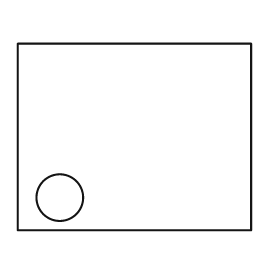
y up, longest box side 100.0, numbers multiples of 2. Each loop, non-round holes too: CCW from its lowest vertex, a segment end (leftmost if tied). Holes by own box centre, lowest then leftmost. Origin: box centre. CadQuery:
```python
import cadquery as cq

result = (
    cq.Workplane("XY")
    .moveTo(-50.0, -40.0)
    .lineTo(50.0, -40.0)
    .lineTo(50.0, 40.0)
    .lineTo(-50.0, 40.0)
    .close()
    .moveTo(-32.0, -26.0)
    .circle(10.0)
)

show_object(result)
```